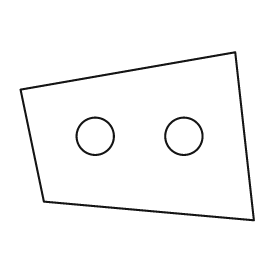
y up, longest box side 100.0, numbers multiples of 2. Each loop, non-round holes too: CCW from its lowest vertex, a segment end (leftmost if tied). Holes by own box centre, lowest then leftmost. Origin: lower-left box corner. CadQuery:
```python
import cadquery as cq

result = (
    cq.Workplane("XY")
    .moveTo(100.0, 0.0)
    .lineTo(92.0, 72.0)
    .lineTo(0.0, 56.0)
    .lineTo(10.0, 8.0)
    .close()
    .moveTo(32.0, 36.0)
    .circle(8.0)
    .moveTo(70.0, 36.0)
    .circle(8.0)
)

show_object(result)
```